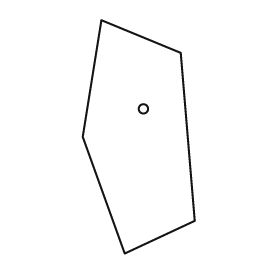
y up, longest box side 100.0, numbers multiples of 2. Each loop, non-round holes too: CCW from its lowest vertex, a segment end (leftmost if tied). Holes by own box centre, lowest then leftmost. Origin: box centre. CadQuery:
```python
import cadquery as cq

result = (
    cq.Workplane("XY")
    .moveTo(-6.0, -50.0)
    .lineTo(24.0, -36.0)
    .lineTo(18.0, 36.0)
    .lineTo(-16.0, 50.0)
    .lineTo(-24.0, 0.0)
    .close()
    .moveTo(2.0, 12.0)
    .circle(2.0)
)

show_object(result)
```